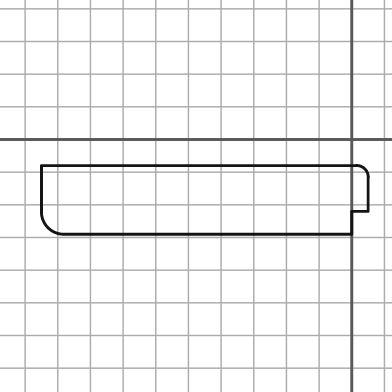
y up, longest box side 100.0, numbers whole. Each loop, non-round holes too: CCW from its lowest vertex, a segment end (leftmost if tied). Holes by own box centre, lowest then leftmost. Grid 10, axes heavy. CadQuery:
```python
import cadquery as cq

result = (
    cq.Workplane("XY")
    .moveTo(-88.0, -29.0)
    .lineTo(0.0, -29.0)
    .lineTo(0.0, -22.0)
    .lineTo(5.0, -22.0)
    .lineTo(5.0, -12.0)
    .threePointArc((4.0, -9.0), (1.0, -8.0))
    .lineTo(-95.0, -8.0)
    .lineTo(-95.0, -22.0)
    .threePointArc((-93.0, -27.0), (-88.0, -29.0))
    .close()
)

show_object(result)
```